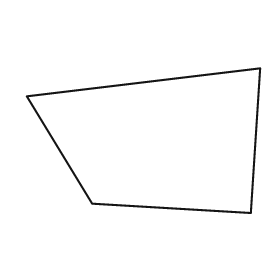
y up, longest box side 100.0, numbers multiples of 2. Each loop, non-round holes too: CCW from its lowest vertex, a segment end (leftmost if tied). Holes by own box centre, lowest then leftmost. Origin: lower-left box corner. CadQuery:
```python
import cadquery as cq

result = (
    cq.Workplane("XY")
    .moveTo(96.0, 0.0)
    .lineTo(100.0, 62.0)
    .lineTo(0.0, 50.0)
    .lineTo(28.0, 4.0)
    .close()
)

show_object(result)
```